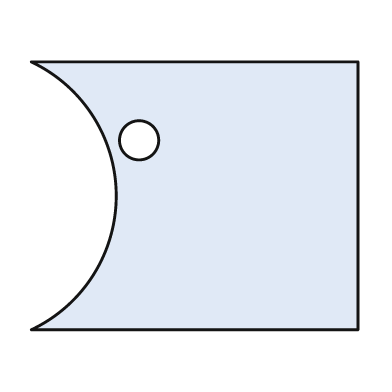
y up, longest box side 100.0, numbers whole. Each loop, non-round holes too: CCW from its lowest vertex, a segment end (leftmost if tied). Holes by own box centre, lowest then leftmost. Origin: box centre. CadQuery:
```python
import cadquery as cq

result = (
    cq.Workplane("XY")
    .moveTo(-50.0, -41.0)
    .lineTo(50.0, -41.0)
    .lineTo(50.0, 41.0)
    .lineTo(-50.0, 41.0)
    .threePointArc((-24.0, 0.0), (-50.0, -41.0))
    .close()
    .moveTo(-17.0, 17.0)
    .circle(6.0)
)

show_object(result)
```